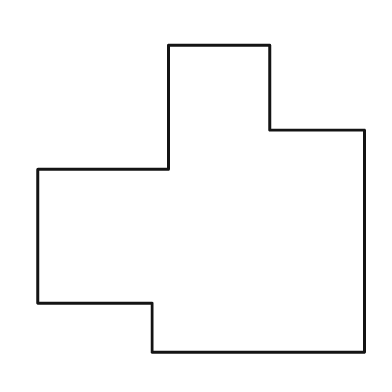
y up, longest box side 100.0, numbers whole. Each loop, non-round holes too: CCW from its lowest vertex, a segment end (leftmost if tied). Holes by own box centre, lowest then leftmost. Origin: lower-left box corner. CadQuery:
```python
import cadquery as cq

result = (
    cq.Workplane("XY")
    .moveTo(35.0, 0.0)
    .lineTo(100.0, 0.0)
    .lineTo(100.0, 68.0)
    .lineTo(71.0, 68.0)
    .lineTo(71.0, 94.0)
    .lineTo(40.0, 94.0)
    .lineTo(40.0, 56.0)
    .lineTo(0.0, 56.0)
    .lineTo(0.0, 15.0)
    .lineTo(35.0, 15.0)
    .close()
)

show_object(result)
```